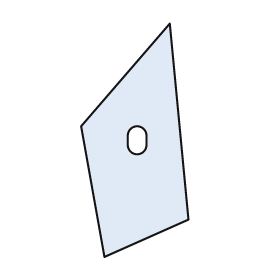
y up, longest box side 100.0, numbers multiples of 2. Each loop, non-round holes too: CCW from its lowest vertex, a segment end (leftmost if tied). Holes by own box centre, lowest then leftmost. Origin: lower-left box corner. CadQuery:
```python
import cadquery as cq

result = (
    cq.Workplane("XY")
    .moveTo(10.0, 0.0)
    .lineTo(46.0, 16.0)
    .lineTo(38.0, 100.0)
    .lineTo(0.0, 56.0)
    .close()
    .moveTo(20.0, 48.0)
    .threePointArc((24.0, 44.0), (28.0, 48.0))
    .lineTo(28.0, 52.0)
    .threePointArc((24.0, 56.0), (20.0, 52.0))
    .close()
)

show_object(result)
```